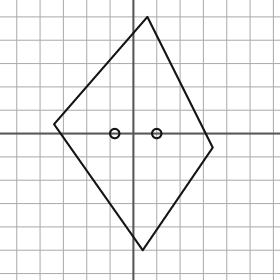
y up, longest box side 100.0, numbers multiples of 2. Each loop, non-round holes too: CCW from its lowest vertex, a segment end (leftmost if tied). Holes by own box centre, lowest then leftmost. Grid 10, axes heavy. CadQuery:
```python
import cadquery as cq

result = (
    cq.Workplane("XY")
    .moveTo(4.0, -50.0)
    .lineTo(34.0, -6.0)
    .lineTo(6.0, 50.0)
    .lineTo(-34.0, 4.0)
    .close()
    .moveTo(-8.0, 0.0)
    .circle(2.0)
    .moveTo(10.0, 0.0)
    .circle(2.0)
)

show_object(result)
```